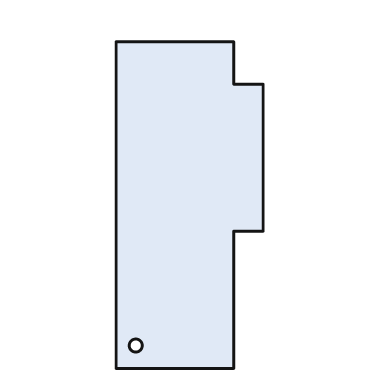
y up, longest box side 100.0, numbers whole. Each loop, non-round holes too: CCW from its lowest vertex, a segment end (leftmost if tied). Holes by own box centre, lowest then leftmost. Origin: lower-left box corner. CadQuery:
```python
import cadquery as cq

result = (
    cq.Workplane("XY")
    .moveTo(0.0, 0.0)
    .lineTo(36.0, 0.0)
    .lineTo(36.0, 42.0)
    .lineTo(45.0, 42.0)
    .lineTo(45.0, 87.0)
    .lineTo(36.0, 87.0)
    .lineTo(36.0, 100.0)
    .lineTo(0.0, 100.0)
    .close()
    .moveTo(6.0, 7.0)
    .circle(2.0)
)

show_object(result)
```